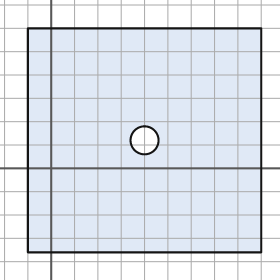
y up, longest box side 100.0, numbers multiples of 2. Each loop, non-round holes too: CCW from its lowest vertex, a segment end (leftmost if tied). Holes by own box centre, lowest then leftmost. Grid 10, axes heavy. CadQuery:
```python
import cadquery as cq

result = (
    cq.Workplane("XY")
    .moveTo(-10.0, -36.0)
    .lineTo(90.0, -36.0)
    .lineTo(90.0, 60.0)
    .lineTo(-10.0, 60.0)
    .close()
    .moveTo(40.0, 12.0)
    .circle(6.0)
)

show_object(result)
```